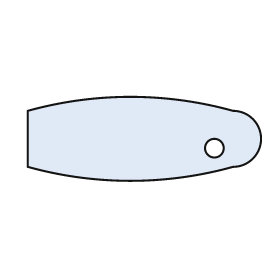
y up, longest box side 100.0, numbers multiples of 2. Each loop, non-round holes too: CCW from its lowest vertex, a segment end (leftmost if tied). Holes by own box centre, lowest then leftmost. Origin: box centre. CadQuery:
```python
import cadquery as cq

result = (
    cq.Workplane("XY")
    .moveTo(-50.0, -12.0)
    .threePointArc((-6.0, -18.0), (38.0, -12.0))
    .threePointArc((50.0, 0.0), (38.0, 12.0))
    .threePointArc((-6.0, 18.0), (-50.0, 12.0))
    .close()
    .moveTo(30.0, -4.0)
    .circle(4.0)
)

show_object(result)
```